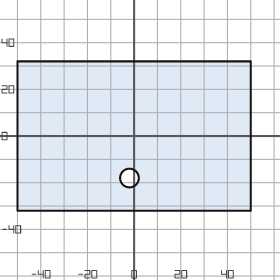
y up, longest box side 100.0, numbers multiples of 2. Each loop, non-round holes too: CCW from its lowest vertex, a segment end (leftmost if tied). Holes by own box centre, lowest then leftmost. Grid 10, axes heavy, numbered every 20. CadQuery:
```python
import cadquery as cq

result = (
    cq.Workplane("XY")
    .moveTo(-50.0, -32.0)
    .lineTo(50.0, -32.0)
    .lineTo(50.0, 32.0)
    .lineTo(-50.0, 32.0)
    .close()
    .moveTo(-2.0, -18.0)
    .circle(4.0)
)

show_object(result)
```